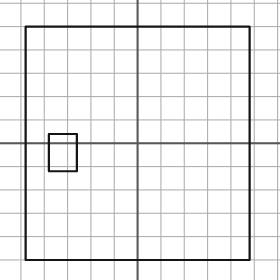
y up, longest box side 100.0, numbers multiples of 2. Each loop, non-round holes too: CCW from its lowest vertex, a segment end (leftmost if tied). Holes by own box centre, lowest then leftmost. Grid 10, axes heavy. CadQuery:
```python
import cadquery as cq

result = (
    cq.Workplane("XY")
    .moveTo(-48.0, -50.0)
    .lineTo(48.0, -50.0)
    .lineTo(48.0, 50.0)
    .lineTo(-48.0, 50.0)
    .close()
    .moveTo(-38.0, -12.0)
    .lineTo(-26.0, -12.0)
    .lineTo(-26.0, 4.0)
    .lineTo(-38.0, 4.0)
    .close()
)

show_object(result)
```